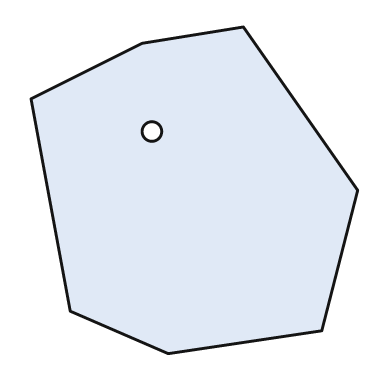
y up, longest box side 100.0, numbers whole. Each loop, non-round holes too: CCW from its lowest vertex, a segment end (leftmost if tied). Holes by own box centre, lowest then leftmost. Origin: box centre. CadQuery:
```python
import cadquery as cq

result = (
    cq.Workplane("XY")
    .moveTo(-8.0, -50.0)
    .lineTo(39.0, -43.0)
    .lineTo(50.0, 0.0)
    .lineTo(15.0, 50.0)
    .lineTo(-16.0, 45.0)
    .lineTo(-50.0, 28.0)
    .lineTo(-38.0, -37.0)
    .close()
    .moveTo(-13.0, 18.0)
    .circle(3.0)
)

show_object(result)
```